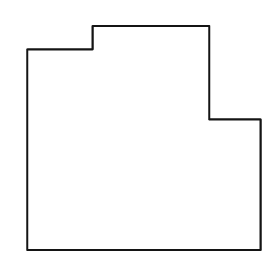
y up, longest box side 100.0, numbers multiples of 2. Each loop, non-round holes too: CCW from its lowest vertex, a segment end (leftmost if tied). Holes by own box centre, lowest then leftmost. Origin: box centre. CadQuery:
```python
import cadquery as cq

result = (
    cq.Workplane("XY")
    .moveTo(-50.0, -48.0)
    .lineTo(50.0, -48.0)
    .lineTo(50.0, 8.0)
    .lineTo(28.0, 8.0)
    .lineTo(28.0, 48.0)
    .lineTo(-22.0, 48.0)
    .lineTo(-22.0, 38.0)
    .lineTo(-50.0, 38.0)
    .close()
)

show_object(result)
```